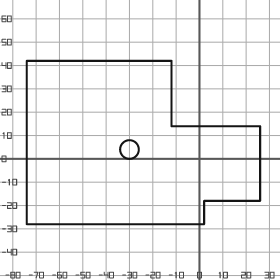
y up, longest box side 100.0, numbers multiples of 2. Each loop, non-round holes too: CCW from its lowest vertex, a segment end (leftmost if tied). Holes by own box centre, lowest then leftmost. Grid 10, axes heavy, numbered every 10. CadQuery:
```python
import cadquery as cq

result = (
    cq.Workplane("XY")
    .moveTo(-74.0, -28.0)
    .lineTo(2.0, -28.0)
    .lineTo(2.0, -18.0)
    .lineTo(26.0, -18.0)
    .lineTo(26.0, 14.0)
    .lineTo(-12.0, 14.0)
    .lineTo(-12.0, 42.0)
    .lineTo(-74.0, 42.0)
    .close()
    .moveTo(-30.0, 4.0)
    .circle(4.0)
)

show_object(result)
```